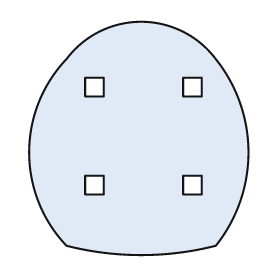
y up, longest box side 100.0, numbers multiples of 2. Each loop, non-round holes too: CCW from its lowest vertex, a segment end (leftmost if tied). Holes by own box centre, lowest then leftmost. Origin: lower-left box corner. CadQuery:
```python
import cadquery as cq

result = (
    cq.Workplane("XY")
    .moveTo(16.0, 4.0)
    .threePointArc((48.0, 0.0), (80.0, 4.0))
    .threePointArc((94.0, 44.0), (80.0, 84.0))
    .threePointArc((48.0, 100.0), (16.0, 84.0))
    .threePointArc((0.0, 44.0), (16.0, 4.0))
    .close()
    .moveTo(24.0, 26.0)
    .lineTo(32.0, 26.0)
    .lineTo(32.0, 34.0)
    .lineTo(24.0, 34.0)
    .close()
    .moveTo(66.0, 26.0)
    .lineTo(74.0, 26.0)
    .lineTo(74.0, 34.0)
    .lineTo(66.0, 34.0)
    .close()
    .moveTo(24.0, 68.0)
    .lineTo(32.0, 68.0)
    .lineTo(32.0, 76.0)
    .lineTo(24.0, 76.0)
    .close()
    .moveTo(66.0, 68.0)
    .lineTo(74.0, 68.0)
    .lineTo(74.0, 76.0)
    .lineTo(66.0, 76.0)
    .close()
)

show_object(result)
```